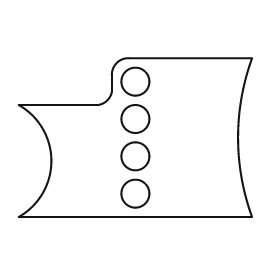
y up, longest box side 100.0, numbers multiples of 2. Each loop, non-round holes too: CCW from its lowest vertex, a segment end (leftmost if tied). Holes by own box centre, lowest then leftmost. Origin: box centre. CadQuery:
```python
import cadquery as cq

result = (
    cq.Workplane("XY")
    .moveTo(-50.0, -34.0)
    .lineTo(50.0, -34.0)
    .threePointArc((44.0, 0.0), (50.0, 34.0))
    .lineTo(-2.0, 34.0)
    .threePointArc((-8.0, 32.0), (-10.0, 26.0))
    .lineTo(-10.0, 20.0)
    .threePointArc((-12.0, 16.0), (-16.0, 14.0))
    .lineTo(-50.0, 14.0)
    .threePointArc((-36.0, -10.0), (-50.0, -34.0))
    .close()
    .moveTo(0.0, -24.0)
    .circle(6.0)
    .moveTo(0.0, -8.0)
    .circle(6.0)
    .moveTo(0.0, 8.0)
    .circle(6.0)
    .moveTo(0.0, 24.0)
    .circle(6.0)
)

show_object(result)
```